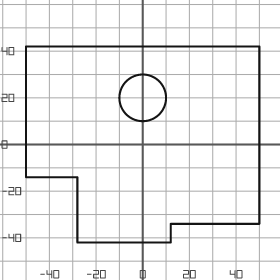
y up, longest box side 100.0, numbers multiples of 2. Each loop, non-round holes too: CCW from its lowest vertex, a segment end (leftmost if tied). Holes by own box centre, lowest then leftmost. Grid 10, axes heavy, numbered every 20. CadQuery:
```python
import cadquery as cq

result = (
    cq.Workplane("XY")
    .moveTo(-28.0, -42.0)
    .lineTo(12.0, -42.0)
    .lineTo(12.0, -34.0)
    .lineTo(50.0, -34.0)
    .lineTo(50.0, 42.0)
    .lineTo(-50.0, 42.0)
    .lineTo(-50.0, -14.0)
    .lineTo(-28.0, -14.0)
    .close()
    .moveTo(0.0, 20.0)
    .circle(10.0)
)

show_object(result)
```